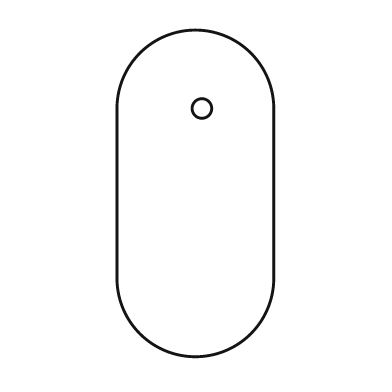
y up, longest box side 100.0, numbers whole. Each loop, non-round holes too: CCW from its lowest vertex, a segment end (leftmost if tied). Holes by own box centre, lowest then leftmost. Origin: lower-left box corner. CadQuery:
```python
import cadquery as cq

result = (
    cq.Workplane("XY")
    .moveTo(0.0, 24.0)
    .threePointArc((24.0, 0.0), (48.0, 24.0))
    .lineTo(48.0, 76.0)
    .threePointArc((24.0, 100.0), (0.0, 76.0))
    .close()
    .moveTo(26.0, 76.0)
    .circle(3.0)
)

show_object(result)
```